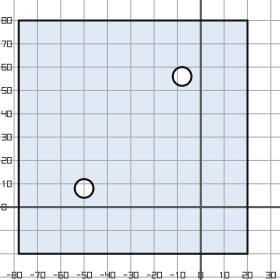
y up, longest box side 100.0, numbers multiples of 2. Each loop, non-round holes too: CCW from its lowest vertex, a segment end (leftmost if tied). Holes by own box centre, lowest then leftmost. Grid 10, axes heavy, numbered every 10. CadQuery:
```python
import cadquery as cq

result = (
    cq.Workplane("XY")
    .moveTo(-78.0, -20.0)
    .lineTo(20.0, -20.0)
    .lineTo(20.0, 80.0)
    .lineTo(-78.0, 80.0)
    .close()
    .moveTo(-50.0, 8.0)
    .circle(4.0)
    .moveTo(-8.0, 56.0)
    .circle(4.0)
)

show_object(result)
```